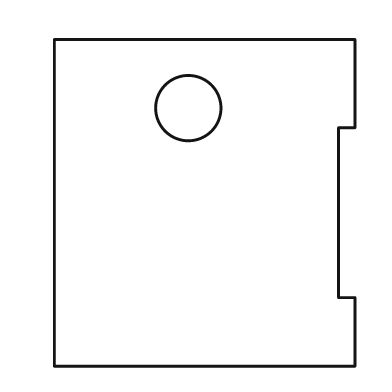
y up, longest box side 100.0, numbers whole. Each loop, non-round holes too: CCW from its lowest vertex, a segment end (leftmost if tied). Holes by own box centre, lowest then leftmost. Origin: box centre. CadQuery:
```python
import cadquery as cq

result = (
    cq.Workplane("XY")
    .moveTo(-46.0, -50.0)
    .lineTo(46.0, -50.0)
    .lineTo(46.0, -29.0)
    .lineTo(41.0, -29.0)
    .lineTo(41.0, 23.0)
    .lineTo(46.0, 23.0)
    .lineTo(46.0, 50.0)
    .lineTo(-46.0, 50.0)
    .close()
    .moveTo(-5.0, 29.0)
    .circle(10.0)
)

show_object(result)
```